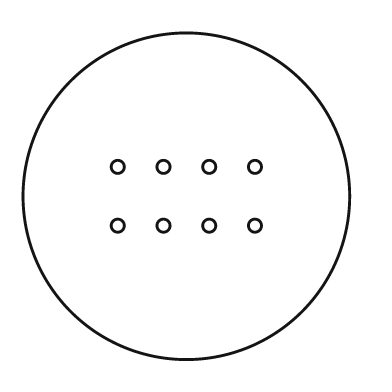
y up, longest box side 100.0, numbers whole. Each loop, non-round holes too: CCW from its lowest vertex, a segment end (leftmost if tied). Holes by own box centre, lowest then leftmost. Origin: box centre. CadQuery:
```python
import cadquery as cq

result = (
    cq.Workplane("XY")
    .moveTo(0.0, 0.0)
    .circle(50.0)
    .moveTo(-21.0, -9.0)
    .circle(2.0)
    .moveTo(-7.0, -9.0)
    .circle(2.0)
    .moveTo(7.0, -9.0)
    .circle(2.0)
    .moveTo(21.0, -9.0)
    .circle(2.0)
    .moveTo(-21.0, 9.0)
    .circle(2.0)
    .moveTo(-7.0, 9.0)
    .circle(2.0)
    .moveTo(7.0, 9.0)
    .circle(2.0)
    .moveTo(21.0, 9.0)
    .circle(2.0)
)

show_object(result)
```